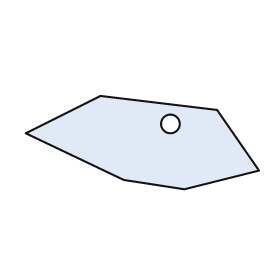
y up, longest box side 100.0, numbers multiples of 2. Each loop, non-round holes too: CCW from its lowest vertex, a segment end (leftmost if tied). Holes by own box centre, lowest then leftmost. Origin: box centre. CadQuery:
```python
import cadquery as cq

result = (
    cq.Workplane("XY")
    .moveTo(18.0, -20.0)
    .lineTo(50.0, -12.0)
    .lineTo(32.0, 14.0)
    .lineTo(-18.0, 20.0)
    .lineTo(-50.0, 4.0)
    .lineTo(-8.0, -16.0)
    .close()
    .moveTo(12.0, 8.0)
    .circle(4.0)
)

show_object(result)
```